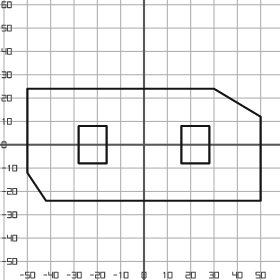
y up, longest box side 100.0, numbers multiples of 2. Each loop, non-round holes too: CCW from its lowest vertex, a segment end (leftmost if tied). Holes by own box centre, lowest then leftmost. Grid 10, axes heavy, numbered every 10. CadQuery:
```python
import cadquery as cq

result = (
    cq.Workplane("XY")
    .moveTo(-42.0, -24.0)
    .lineTo(50.0, -24.0)
    .lineTo(50.0, 12.0)
    .lineTo(30.0, 24.0)
    .lineTo(-50.0, 24.0)
    .lineTo(-50.0, -12.0)
    .close()
    .moveTo(-28.0, -8.0)
    .lineTo(-16.0, -8.0)
    .lineTo(-16.0, 8.0)
    .lineTo(-28.0, 8.0)
    .close()
    .moveTo(16.0, -8.0)
    .lineTo(28.0, -8.0)
    .lineTo(28.0, 8.0)
    .lineTo(16.0, 8.0)
    .close()
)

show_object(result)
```